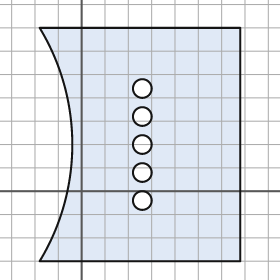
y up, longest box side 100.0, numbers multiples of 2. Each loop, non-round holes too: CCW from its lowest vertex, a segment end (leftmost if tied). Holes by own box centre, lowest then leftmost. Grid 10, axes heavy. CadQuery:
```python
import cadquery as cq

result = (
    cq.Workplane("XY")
    .moveTo(-18.0, -30.0)
    .lineTo(68.0, -30.0)
    .lineTo(68.0, 70.0)
    .lineTo(-18.0, 70.0)
    .threePointArc((-4.0, 20.0), (-18.0, -30.0))
    .close()
    .moveTo(26.0, -4.0)
    .circle(4.0)
    .moveTo(26.0, 8.0)
    .circle(4.0)
    .moveTo(26.0, 20.0)
    .circle(4.0)
    .moveTo(26.0, 32.0)
    .circle(4.0)
    .moveTo(26.0, 44.0)
    .circle(4.0)
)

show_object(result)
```